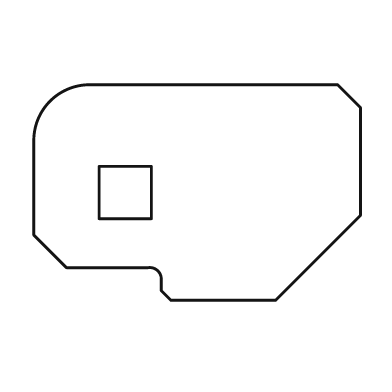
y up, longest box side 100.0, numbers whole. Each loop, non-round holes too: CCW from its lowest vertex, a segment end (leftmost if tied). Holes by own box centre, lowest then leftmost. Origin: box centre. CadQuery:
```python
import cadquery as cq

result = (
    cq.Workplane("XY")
    .moveTo(-8.0, -33.0)
    .lineTo(24.0, -33.0)
    .lineTo(50.0, -7.0)
    .lineTo(50.0, 26.0)
    .lineTo(43.0, 33.0)
    .lineTo(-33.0, 33.0)
    .threePointArc((-45.0, 28.0), (-50.0, 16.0))
    .lineTo(-50.0, -13.0)
    .lineTo(-40.0, -23.0)
    .lineTo(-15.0, -23.0)
    .threePointArc((-12.0, -24.0), (-11.0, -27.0))
    .lineTo(-11.0, -30.0)
    .close()
    .moveTo(-30.0, -8.0)
    .lineTo(-14.0, -8.0)
    .lineTo(-14.0, 8.0)
    .lineTo(-30.0, 8.0)
    .close()
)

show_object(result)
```